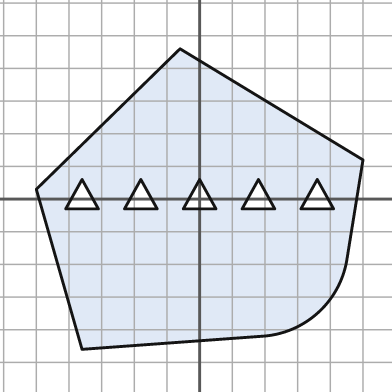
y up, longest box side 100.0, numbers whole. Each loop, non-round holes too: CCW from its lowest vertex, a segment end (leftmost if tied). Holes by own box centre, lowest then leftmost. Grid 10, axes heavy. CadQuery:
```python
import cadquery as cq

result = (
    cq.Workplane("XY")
    .moveTo(-36.0, -46.0)
    .lineTo(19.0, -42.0)
    .threePointArc((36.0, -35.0), (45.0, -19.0))
    .lineTo(50.0, 12.0)
    .lineTo(-6.0, 46.0)
    .lineTo(-50.0, 3.0)
    .close()
    .moveTo(-41.0, -3.0)
    .lineTo(-31.0, -3.0)
    .lineTo(-36.0, 6.0)
    .close()
    .moveTo(-23.0, -3.0)
    .lineTo(-13.0, -3.0)
    .lineTo(-18.0, 6.0)
    .close()
    .moveTo(-5.0, -3.0)
    .lineTo(5.0, -3.0)
    .lineTo(0.0, 6.0)
    .close()
    .moveTo(13.0, -3.0)
    .lineTo(23.0, -3.0)
    .lineTo(18.0, 6.0)
    .close()
    .moveTo(31.0, -3.0)
    .lineTo(41.0, -3.0)
    .lineTo(36.0, 6.0)
    .close()
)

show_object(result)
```